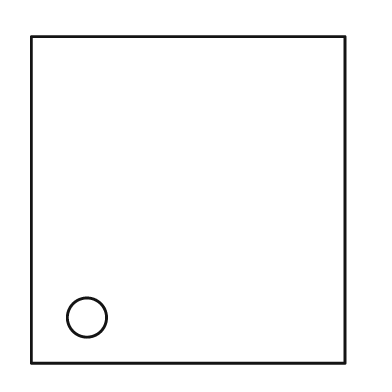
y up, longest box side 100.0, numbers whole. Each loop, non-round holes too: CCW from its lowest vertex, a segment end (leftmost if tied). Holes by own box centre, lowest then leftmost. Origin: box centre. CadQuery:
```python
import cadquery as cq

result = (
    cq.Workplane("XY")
    .moveTo(-48.0, -50.0)
    .lineTo(48.0, -50.0)
    .lineTo(48.0, 50.0)
    .lineTo(-48.0, 50.0)
    .close()
    .moveTo(-31.0, -36.0)
    .circle(6.0)
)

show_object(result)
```